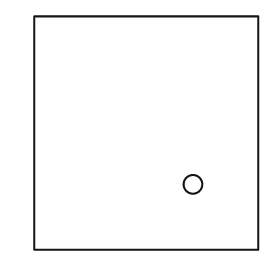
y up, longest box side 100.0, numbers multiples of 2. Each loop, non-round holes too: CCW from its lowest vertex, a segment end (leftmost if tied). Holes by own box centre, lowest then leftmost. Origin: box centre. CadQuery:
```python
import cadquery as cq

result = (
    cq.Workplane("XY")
    .moveTo(-48.0, -50.0)
    .lineTo(48.0, -50.0)
    .lineTo(48.0, 50.0)
    .lineTo(-48.0, 50.0)
    .close()
    .moveTo(20.0, -22.0)
    .circle(4.0)
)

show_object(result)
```